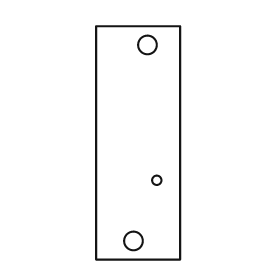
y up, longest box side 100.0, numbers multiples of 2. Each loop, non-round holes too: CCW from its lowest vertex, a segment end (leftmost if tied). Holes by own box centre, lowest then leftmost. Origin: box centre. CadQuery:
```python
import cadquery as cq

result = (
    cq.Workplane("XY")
    .moveTo(-18.0, -50.0)
    .lineTo(18.0, -50.0)
    .lineTo(18.0, 50.0)
    .lineTo(-18.0, 50.0)
    .close()
    .moveTo(-2.0, -42.0)
    .circle(4.0)
    .moveTo(8.0, -16.0)
    .circle(2.0)
    .moveTo(4.0, 42.0)
    .circle(4.0)
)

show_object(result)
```